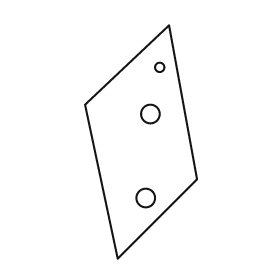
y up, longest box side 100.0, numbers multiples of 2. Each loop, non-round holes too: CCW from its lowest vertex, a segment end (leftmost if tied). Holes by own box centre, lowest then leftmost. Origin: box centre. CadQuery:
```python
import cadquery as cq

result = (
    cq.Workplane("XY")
    .moveTo(-10.0, -50.0)
    .lineTo(24.0, -16.0)
    .lineTo(12.0, 50.0)
    .lineTo(-24.0, 16.0)
    .close()
    .moveTo(2.0, -24.0)
    .circle(4.0)
    .moveTo(4.0, 12.0)
    .circle(4.0)
    .moveTo(8.0, 32.0)
    .circle(2.0)
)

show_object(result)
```